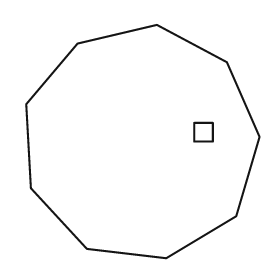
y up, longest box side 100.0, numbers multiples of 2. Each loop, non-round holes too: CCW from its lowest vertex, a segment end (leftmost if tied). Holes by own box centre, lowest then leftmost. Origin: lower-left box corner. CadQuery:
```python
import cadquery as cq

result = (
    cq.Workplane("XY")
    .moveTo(60.0, 0.0)
    .lineTo(90.0, 18.0)
    .lineTo(100.0, 52.0)
    .lineTo(86.0, 84.0)
    .lineTo(56.0, 100.0)
    .lineTo(22.0, 92.0)
    .lineTo(0.0, 66.0)
    .lineTo(2.0, 30.0)
    .lineTo(26.0, 4.0)
    .close()
    .moveTo(72.0, 50.0)
    .lineTo(80.0, 50.0)
    .lineTo(80.0, 58.0)
    .lineTo(72.0, 58.0)
    .close()
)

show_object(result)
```